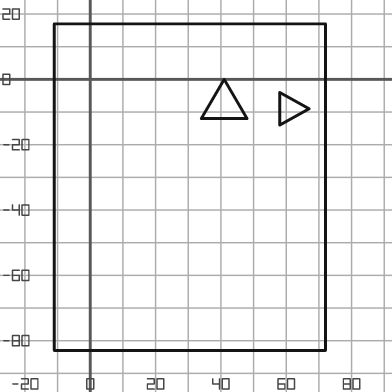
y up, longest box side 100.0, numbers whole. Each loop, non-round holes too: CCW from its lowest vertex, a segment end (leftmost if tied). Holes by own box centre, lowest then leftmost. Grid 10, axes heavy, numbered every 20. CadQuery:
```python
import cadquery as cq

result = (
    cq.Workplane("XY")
    .moveTo(-11.0, -83.0)
    .lineTo(72.0, -83.0)
    .lineTo(72.0, 17.0)
    .lineTo(-11.0, 17.0)
    .close()
    .moveTo(58.0, -14.0)
    .lineTo(67.0, -9.0)
    .lineTo(58.0, -4.0)
    .close()
    .moveTo(34.0, -12.0)
    .lineTo(48.0, -12.0)
    .lineTo(41.0, 0.0)
    .close()
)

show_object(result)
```